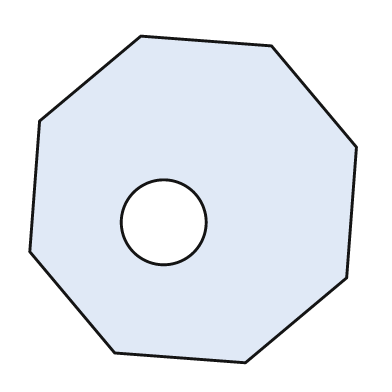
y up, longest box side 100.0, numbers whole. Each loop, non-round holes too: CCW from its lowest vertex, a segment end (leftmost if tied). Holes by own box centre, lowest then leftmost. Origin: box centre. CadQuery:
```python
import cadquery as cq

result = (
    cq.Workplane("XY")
    .moveTo(16.0, -50.0)
    .lineTo(47.0, -24.0)
    .lineTo(50.0, 16.0)
    .lineTo(24.0, 47.0)
    .lineTo(-16.0, 50.0)
    .lineTo(-47.0, 24.0)
    .lineTo(-50.0, -16.0)
    .lineTo(-24.0, -47.0)
    .close()
    .moveTo(-9.0, -7.0)
    .circle(13.0)
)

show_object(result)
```